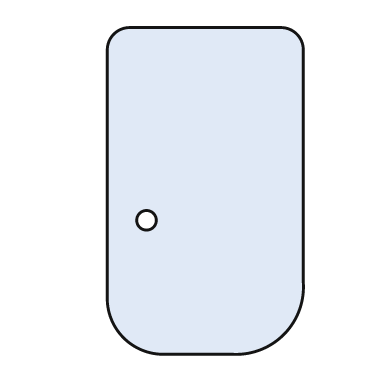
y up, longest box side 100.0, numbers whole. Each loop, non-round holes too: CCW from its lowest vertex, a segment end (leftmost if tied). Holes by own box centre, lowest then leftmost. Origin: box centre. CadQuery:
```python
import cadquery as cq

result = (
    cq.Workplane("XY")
    .moveTo(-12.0, -50.0)
    .lineTo(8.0, -50.0)
    .threePointArc((24.0, -44.0), (30.0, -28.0))
    .lineTo(30.0, 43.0)
    .threePointArc((28.0, 48.0), (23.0, 50.0))
    .lineTo(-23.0, 50.0)
    .threePointArc((-28.0, 48.0), (-30.0, 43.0))
    .lineTo(-30.0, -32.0)
    .threePointArc((-25.0, -45.0), (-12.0, -50.0))
    .close()
    .moveTo(-18.0, -9.0)
    .circle(3.0)
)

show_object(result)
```